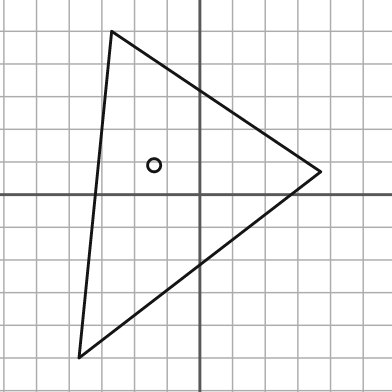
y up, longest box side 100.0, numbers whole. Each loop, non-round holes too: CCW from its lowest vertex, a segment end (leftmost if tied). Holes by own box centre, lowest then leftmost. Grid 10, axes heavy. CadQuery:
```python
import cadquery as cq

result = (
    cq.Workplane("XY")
    .moveTo(-37.0, -50.0)
    .lineTo(37.0, 7.0)
    .lineTo(-27.0, 50.0)
    .close()
    .moveTo(-14.0, 9.0)
    .circle(2.0)
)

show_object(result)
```